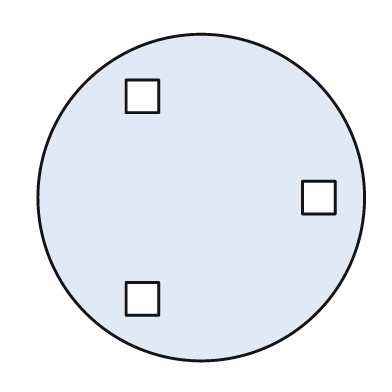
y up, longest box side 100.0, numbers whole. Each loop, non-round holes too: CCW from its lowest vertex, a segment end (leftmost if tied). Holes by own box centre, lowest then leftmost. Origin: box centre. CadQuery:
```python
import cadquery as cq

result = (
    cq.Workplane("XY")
    .moveTo(0.0, 0.0)
    .circle(50.0)
    .moveTo(-23.0, -36.0)
    .lineTo(-13.0, -36.0)
    .lineTo(-13.0, -26.0)
    .lineTo(-23.0, -26.0)
    .close()
    .moveTo(31.0, -5.0)
    .lineTo(41.0, -5.0)
    .lineTo(41.0, 5.0)
    .lineTo(31.0, 5.0)
    .close()
    .moveTo(-23.0, 26.0)
    .lineTo(-13.0, 26.0)
    .lineTo(-13.0, 36.0)
    .lineTo(-23.0, 36.0)
    .close()
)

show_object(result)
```